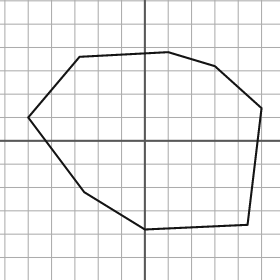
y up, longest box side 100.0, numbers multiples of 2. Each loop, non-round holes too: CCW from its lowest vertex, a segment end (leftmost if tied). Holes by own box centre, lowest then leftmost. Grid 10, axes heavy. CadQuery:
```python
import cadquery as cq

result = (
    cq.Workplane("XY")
    .moveTo(0.0, -38.0)
    .lineTo(44.0, -36.0)
    .lineTo(50.0, 14.0)
    .lineTo(30.0, 32.0)
    .lineTo(10.0, 38.0)
    .lineTo(-28.0, 36.0)
    .lineTo(-50.0, 10.0)
    .lineTo(-26.0, -22.0)
    .close()
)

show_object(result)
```